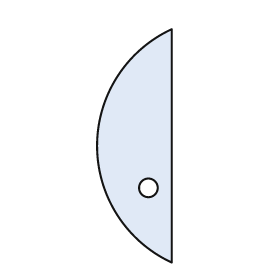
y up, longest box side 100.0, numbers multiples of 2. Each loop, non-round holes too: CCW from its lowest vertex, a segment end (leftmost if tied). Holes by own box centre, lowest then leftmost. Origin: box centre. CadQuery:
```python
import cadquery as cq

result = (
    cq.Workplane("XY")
    .moveTo(16.0, -50.0)
    .lineTo(16.0, 50.0)
    .threePointArc((-16.0, 0.0), (16.0, -50.0))
    .close()
    .moveTo(6.0, -18.0)
    .circle(4.0)
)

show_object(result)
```